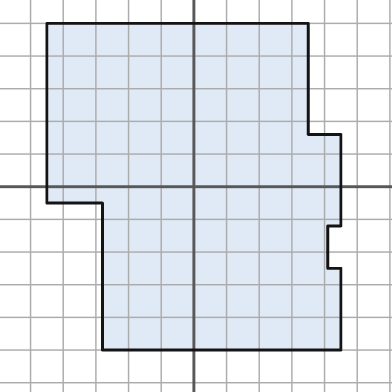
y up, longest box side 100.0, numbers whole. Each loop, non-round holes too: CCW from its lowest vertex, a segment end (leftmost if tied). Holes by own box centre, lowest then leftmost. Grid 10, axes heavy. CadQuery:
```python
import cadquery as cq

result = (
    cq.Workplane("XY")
    .moveTo(-28.0, -50.0)
    .lineTo(45.0, -50.0)
    .lineTo(45.0, -25.0)
    .lineTo(41.0, -25.0)
    .lineTo(41.0, -12.0)
    .lineTo(45.0, -12.0)
    .lineTo(45.0, 16.0)
    .lineTo(35.0, 16.0)
    .lineTo(35.0, 50.0)
    .lineTo(-45.0, 50.0)
    .lineTo(-45.0, -5.0)
    .lineTo(-28.0, -5.0)
    .close()
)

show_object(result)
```